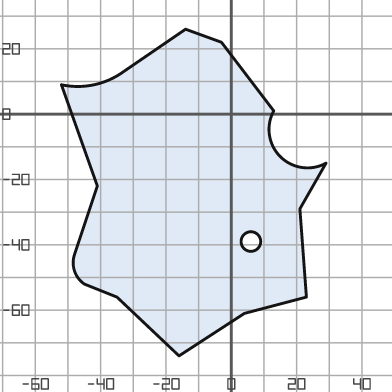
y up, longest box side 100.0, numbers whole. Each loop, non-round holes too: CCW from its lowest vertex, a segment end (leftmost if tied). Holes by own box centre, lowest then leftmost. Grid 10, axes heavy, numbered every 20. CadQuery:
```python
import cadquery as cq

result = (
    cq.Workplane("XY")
    .moveTo(-16.0, -74.0)
    .lineTo(4.0, -61.0)
    .lineTo(23.0, -56.0)
    .lineTo(21.0, -29.0)
    .lineTo(29.0, -15.0)
    .threePointArc((15.0, -13.0), (13.0, 1.0))
    .lineTo(-3.0, 22.0)
    .lineTo(-14.0, 26.0)
    .lineTo(-33.0, 13.0)
    .threePointArc((-42.0, 9.0), (-52.0, 9.0))
    .lineTo(-41.0, -22.0)
    .lineTo(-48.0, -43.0)
    .threePointArc((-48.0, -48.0), (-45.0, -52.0))
    .lineTo(-35.0, -56.0)
    .close()
    .moveTo(6.0, -39.0)
    .circle(3.0)
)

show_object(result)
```